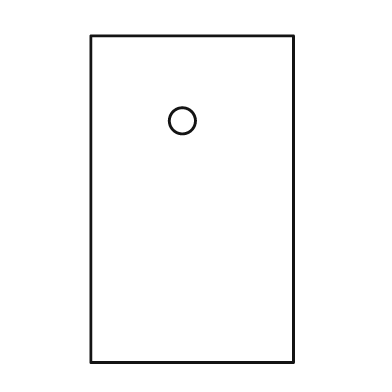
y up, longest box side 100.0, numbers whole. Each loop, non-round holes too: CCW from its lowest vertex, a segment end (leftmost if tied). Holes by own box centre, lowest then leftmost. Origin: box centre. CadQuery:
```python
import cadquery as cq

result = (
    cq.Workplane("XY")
    .moveTo(-31.0, -50.0)
    .lineTo(31.0, -50.0)
    .lineTo(31.0, 50.0)
    .lineTo(-31.0, 50.0)
    .close()
    .moveTo(-3.0, 24.0)
    .circle(4.0)
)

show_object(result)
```